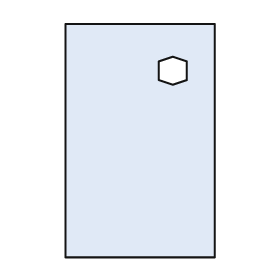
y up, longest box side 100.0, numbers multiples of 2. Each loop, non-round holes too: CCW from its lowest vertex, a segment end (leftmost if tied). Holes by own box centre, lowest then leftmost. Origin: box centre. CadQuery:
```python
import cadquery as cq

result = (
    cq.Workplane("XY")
    .moveTo(-32.0, -50.0)
    .lineTo(32.0, -50.0)
    .lineTo(32.0, 50.0)
    .lineTo(-32.0, 50.0)
    .close()
    .moveTo(14.0, 24.0)
    .lineTo(20.0, 26.0)
    .lineTo(20.0, 34.0)
    .lineTo(14.0, 36.0)
    .lineTo(8.0, 34.0)
    .lineTo(8.0, 26.0)
    .close()
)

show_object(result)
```